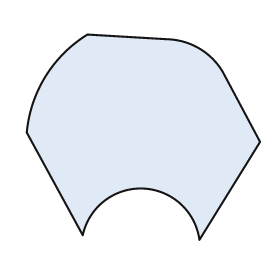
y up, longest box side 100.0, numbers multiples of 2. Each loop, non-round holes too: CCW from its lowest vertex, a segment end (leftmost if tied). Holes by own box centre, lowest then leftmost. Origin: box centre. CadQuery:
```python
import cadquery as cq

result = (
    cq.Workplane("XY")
    .moveTo(24.0, -44.0)
    .lineTo(50.0, -2.0)
    .lineTo(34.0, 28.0)
    .threePointArc((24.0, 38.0), (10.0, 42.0))
    .lineTo(-24.0, 44.0)
    .threePointArc((-42.0, 26.0), (-50.0, 2.0))
    .lineTo(-26.0, -42.0)
    .threePointArc((0.0, -22.0), (24.0, -44.0))
    .close()
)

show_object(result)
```